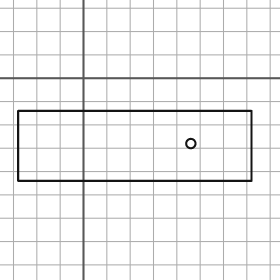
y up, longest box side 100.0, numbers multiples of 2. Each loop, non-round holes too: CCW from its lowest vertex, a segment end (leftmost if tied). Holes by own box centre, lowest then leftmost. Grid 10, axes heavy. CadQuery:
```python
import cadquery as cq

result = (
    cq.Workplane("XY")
    .moveTo(-28.0, -44.0)
    .lineTo(72.0, -44.0)
    .lineTo(72.0, -14.0)
    .lineTo(-28.0, -14.0)
    .close()
    .moveTo(46.0, -28.0)
    .circle(2.0)
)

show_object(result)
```